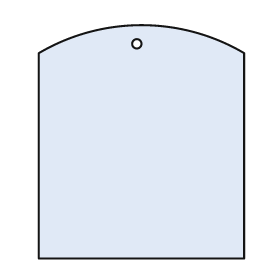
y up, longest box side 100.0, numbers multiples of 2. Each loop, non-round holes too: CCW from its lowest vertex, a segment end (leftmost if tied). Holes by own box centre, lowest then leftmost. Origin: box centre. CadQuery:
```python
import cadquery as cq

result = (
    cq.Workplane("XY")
    .moveTo(-44.0, -50.0)
    .lineTo(44.0, -50.0)
    .lineTo(44.0, 38.0)
    .threePointArc((0.0, 50.0), (-44.0, 38.0))
    .close()
    .moveTo(-2.0, 42.0)
    .circle(2.0)
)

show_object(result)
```